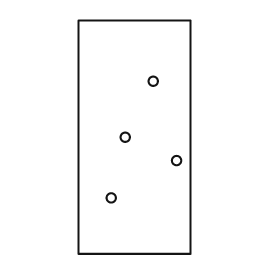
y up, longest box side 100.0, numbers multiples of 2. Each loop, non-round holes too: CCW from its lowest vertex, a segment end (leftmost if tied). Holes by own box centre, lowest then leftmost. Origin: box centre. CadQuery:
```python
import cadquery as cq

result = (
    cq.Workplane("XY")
    .moveTo(-24.0, -50.0)
    .lineTo(24.0, -50.0)
    .lineTo(24.0, 50.0)
    .lineTo(-24.0, 50.0)
    .close()
    .moveTo(-10.0, -26.0)
    .circle(2.0)
    .moveTo(18.0, -10.0)
    .circle(2.0)
    .moveTo(-4.0, 0.0)
    .circle(2.0)
    .moveTo(8.0, 24.0)
    .circle(2.0)
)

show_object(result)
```